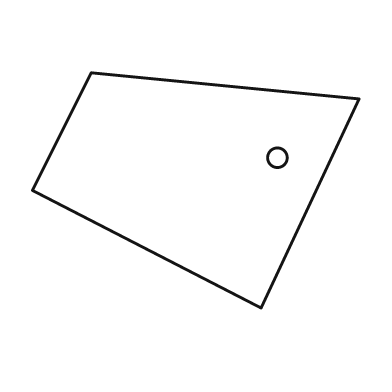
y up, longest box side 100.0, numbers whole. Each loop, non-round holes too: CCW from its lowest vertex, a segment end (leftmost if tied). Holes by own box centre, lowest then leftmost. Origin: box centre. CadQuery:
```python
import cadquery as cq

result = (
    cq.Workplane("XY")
    .moveTo(20.0, -36.0)
    .lineTo(50.0, 28.0)
    .lineTo(-32.0, 36.0)
    .lineTo(-50.0, 0.0)
    .close()
    .moveTo(25.0, 10.0)
    .circle(3.0)
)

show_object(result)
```